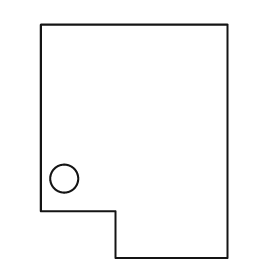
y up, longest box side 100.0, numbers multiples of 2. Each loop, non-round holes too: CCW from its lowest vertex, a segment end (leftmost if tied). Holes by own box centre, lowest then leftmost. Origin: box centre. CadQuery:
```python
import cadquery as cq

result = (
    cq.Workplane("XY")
    .moveTo(-8.0, -50.0)
    .lineTo(40.0, -50.0)
    .lineTo(40.0, 50.0)
    .lineTo(-40.0, 50.0)
    .lineTo(-40.0, -30.0)
    .lineTo(-8.0, -30.0)
    .close()
    .moveTo(-30.0, -16.0)
    .circle(6.0)
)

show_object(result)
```